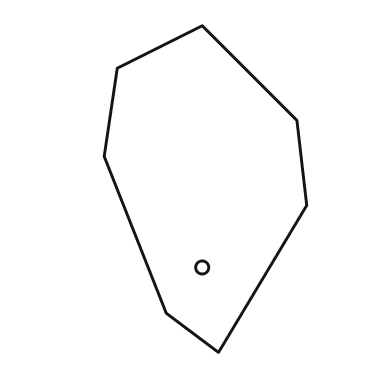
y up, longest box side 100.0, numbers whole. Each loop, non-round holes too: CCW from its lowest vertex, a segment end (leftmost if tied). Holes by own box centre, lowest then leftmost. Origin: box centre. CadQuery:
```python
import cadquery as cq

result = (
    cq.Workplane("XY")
    .moveTo(4.0, -50.0)
    .lineTo(31.0, -5.0)
    .lineTo(28.0, 21.0)
    .lineTo(-1.0, 50.0)
    .lineTo(-27.0, 37.0)
    .lineTo(-31.0, 10.0)
    .lineTo(-12.0, -38.0)
    .close()
    .moveTo(-1.0, -24.0)
    .circle(2.0)
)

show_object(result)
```